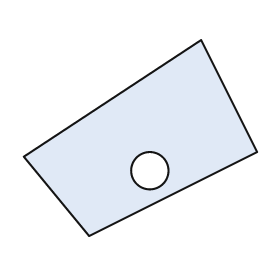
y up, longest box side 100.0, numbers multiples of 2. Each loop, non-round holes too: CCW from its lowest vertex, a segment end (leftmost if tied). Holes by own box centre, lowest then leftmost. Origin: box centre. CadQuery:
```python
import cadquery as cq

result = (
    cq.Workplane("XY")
    .moveTo(-22.0, -42.0)
    .lineTo(50.0, -6.0)
    .lineTo(26.0, 42.0)
    .lineTo(-50.0, -8.0)
    .close()
    .moveTo(4.0, -14.0)
    .circle(8.0)
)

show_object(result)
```